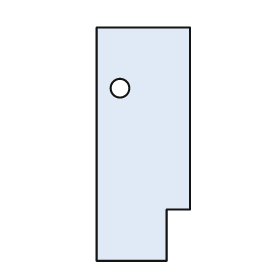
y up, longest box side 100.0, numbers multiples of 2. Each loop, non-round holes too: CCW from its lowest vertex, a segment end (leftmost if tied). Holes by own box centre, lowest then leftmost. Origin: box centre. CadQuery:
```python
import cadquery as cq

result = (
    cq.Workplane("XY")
    .moveTo(-20.0, -50.0)
    .lineTo(10.0, -50.0)
    .lineTo(10.0, -28.0)
    .lineTo(20.0, -28.0)
    .lineTo(20.0, 50.0)
    .lineTo(-20.0, 50.0)
    .close()
    .moveTo(-10.0, 24.0)
    .circle(4.0)
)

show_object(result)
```